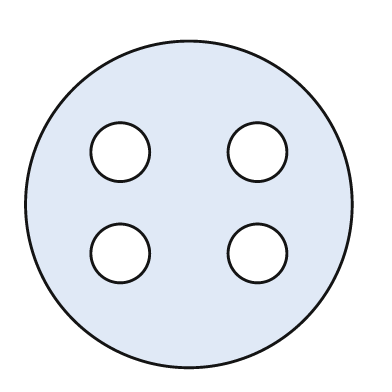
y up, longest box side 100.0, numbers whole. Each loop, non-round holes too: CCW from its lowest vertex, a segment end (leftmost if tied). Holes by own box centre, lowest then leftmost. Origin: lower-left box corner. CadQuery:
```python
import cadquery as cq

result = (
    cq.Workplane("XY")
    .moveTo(50.0, 50.0)
    .circle(50.0)
    .moveTo(29.0, 35.0)
    .circle(9.0)
    .moveTo(71.0, 35.0)
    .circle(9.0)
    .moveTo(29.0, 66.0)
    .circle(9.0)
    .moveTo(71.0, 66.0)
    .circle(9.0)
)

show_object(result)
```